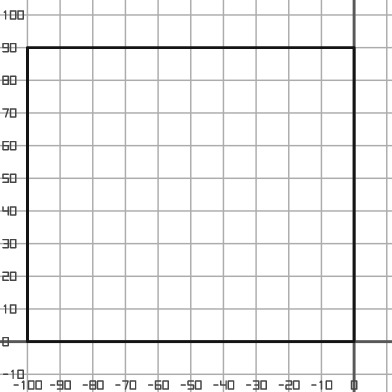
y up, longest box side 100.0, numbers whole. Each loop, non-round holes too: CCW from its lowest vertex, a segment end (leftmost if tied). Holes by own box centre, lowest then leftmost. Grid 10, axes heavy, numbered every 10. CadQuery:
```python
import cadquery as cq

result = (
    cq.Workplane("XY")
    .moveTo(-100.0, 0.0)
    .lineTo(0.0, 0.0)
    .lineTo(0.0, 90.0)
    .lineTo(-100.0, 90.0)
    .close()
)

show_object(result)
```